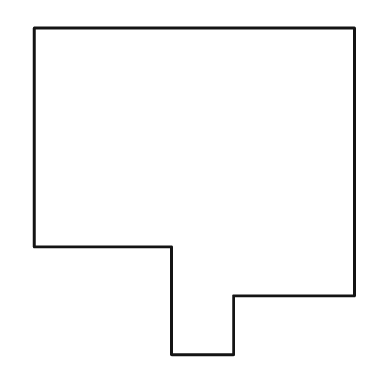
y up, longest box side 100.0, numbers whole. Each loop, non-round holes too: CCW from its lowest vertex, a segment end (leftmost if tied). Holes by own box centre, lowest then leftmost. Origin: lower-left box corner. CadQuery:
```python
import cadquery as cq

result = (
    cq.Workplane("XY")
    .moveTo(42.0, 0.0)
    .lineTo(61.0, 0.0)
    .lineTo(61.0, 18.0)
    .lineTo(98.0, 18.0)
    .lineTo(98.0, 100.0)
    .lineTo(0.0, 100.0)
    .lineTo(0.0, 33.0)
    .lineTo(42.0, 33.0)
    .close()
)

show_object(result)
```